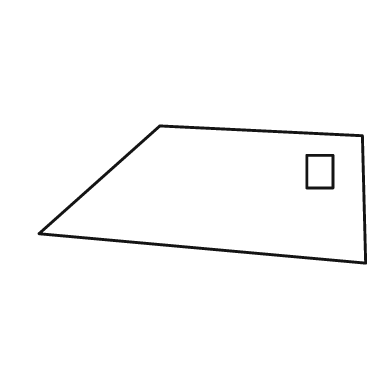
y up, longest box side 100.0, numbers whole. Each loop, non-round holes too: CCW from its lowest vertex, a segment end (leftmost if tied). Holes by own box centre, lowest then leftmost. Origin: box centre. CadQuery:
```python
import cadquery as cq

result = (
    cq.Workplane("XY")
    .moveTo(50.0, -21.0)
    .lineTo(49.0, 18.0)
    .lineTo(-13.0, 21.0)
    .lineTo(-50.0, -12.0)
    .close()
    .moveTo(32.0, 2.0)
    .lineTo(40.0, 2.0)
    .lineTo(40.0, 12.0)
    .lineTo(32.0, 12.0)
    .close()
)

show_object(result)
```